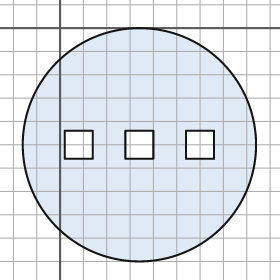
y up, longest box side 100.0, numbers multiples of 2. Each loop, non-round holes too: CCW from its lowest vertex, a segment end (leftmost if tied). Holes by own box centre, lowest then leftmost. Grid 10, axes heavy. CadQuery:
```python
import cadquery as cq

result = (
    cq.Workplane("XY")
    .moveTo(34.0, -50.0)
    .circle(50.0)
    .moveTo(2.0, -56.0)
    .lineTo(14.0, -56.0)
    .lineTo(14.0, -44.0)
    .lineTo(2.0, -44.0)
    .close()
    .moveTo(28.0, -56.0)
    .lineTo(40.0, -56.0)
    .lineTo(40.0, -44.0)
    .lineTo(28.0, -44.0)
    .close()
    .moveTo(54.0, -56.0)
    .lineTo(66.0, -56.0)
    .lineTo(66.0, -44.0)
    .lineTo(54.0, -44.0)
    .close()
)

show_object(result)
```